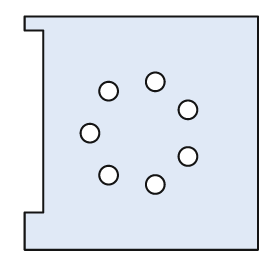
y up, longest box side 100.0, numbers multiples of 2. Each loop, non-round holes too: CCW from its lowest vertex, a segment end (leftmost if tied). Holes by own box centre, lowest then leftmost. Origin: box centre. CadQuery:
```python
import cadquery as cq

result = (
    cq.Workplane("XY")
    .moveTo(-50.0, -50.0)
    .lineTo(50.0, -50.0)
    .lineTo(50.0, 50.0)
    .lineTo(-50.0, 50.0)
    .lineTo(-50.0, 44.0)
    .lineTo(-42.0, 44.0)
    .lineTo(-42.0, -34.0)
    .lineTo(-50.0, -34.0)
    .close()
    .moveTo(6.0, -22.0)
    .circle(4.0)
    .moveTo(-14.0, -18.0)
    .circle(4.0)
    .moveTo(20.0, -10.0)
    .circle(4.0)
    .moveTo(-22.0, 0.0)
    .circle(4.0)
    .moveTo(20.0, 10.0)
    .circle(4.0)
    .moveTo(-14.0, 18.0)
    .circle(4.0)
    .moveTo(6.0, 22.0)
    .circle(4.0)
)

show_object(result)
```